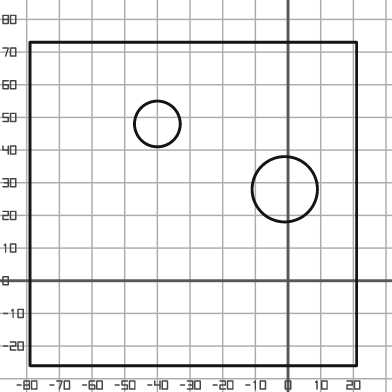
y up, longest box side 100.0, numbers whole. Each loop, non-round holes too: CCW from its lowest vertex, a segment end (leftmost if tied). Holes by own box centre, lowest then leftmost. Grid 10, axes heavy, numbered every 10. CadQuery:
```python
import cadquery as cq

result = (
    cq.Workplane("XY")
    .moveTo(-79.0, -26.0)
    .lineTo(21.0, -26.0)
    .lineTo(21.0, 73.0)
    .lineTo(-79.0, 73.0)
    .close()
    .moveTo(-1.0, 28.0)
    .circle(10.0)
    .moveTo(-40.0, 48.0)
    .circle(7.0)
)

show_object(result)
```